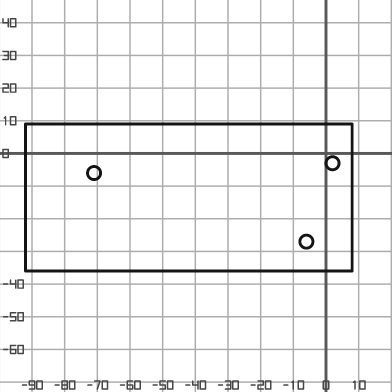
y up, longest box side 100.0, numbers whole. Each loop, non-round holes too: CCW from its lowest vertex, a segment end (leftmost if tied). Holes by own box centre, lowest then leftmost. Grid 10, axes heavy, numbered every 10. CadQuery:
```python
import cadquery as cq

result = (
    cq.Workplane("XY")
    .moveTo(-92.0, -36.0)
    .lineTo(8.0, -36.0)
    .lineTo(8.0, 9.0)
    .lineTo(-92.0, 9.0)
    .close()
    .moveTo(-6.0, -27.0)
    .circle(2.0)
    .moveTo(-71.0, -6.0)
    .circle(2.0)
    .moveTo(2.0, -3.0)
    .circle(2.0)
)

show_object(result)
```